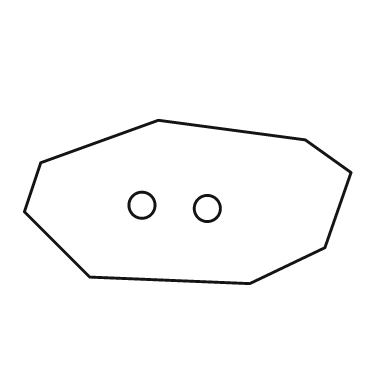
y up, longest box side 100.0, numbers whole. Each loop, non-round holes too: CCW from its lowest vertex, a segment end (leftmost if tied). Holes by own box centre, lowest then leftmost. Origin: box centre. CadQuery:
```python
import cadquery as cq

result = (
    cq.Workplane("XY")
    .moveTo(19.0, -25.0)
    .lineTo(42.0, -14.0)
    .lineTo(50.0, 9.0)
    .lineTo(36.0, 19.0)
    .lineTo(-9.0, 25.0)
    .lineTo(-45.0, 12.0)
    .lineTo(-50.0, -3.0)
    .lineTo(-30.0, -23.0)
    .close()
    .moveTo(6.0, -2.0)
    .circle(4.0)
    .moveTo(-14.0, -1.0)
    .circle(4.0)
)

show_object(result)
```